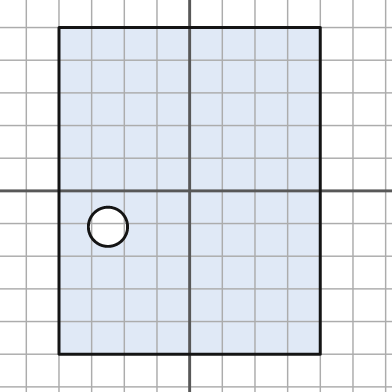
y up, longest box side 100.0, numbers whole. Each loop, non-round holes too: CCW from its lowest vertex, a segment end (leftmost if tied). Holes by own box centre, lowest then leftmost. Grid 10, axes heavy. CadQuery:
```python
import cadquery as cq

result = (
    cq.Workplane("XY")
    .moveTo(-40.0, -50.0)
    .lineTo(40.0, -50.0)
    .lineTo(40.0, 50.0)
    .lineTo(-40.0, 50.0)
    .close()
    .moveTo(-25.0, -11.0)
    .circle(6.0)
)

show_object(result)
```